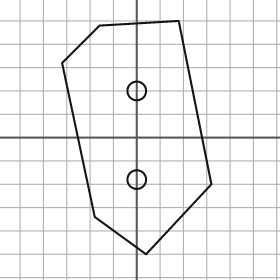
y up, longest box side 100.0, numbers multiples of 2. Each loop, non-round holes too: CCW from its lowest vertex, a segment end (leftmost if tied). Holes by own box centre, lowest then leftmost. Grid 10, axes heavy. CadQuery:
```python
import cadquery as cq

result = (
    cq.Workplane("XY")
    .moveTo(4.0, -50.0)
    .lineTo(32.0, -20.0)
    .lineTo(18.0, 50.0)
    .lineTo(-16.0, 48.0)
    .lineTo(-32.0, 32.0)
    .lineTo(-18.0, -34.0)
    .close()
    .moveTo(0.0, -18.0)
    .circle(4.0)
    .moveTo(0.0, 20.0)
    .circle(4.0)
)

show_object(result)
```